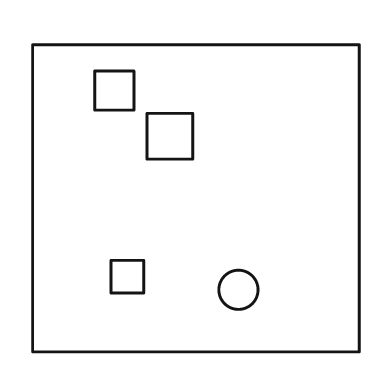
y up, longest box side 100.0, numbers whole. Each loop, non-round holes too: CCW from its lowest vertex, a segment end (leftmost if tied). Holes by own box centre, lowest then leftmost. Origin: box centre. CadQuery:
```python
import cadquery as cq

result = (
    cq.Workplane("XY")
    .moveTo(-50.0, -47.0)
    .lineTo(50.0, -47.0)
    .lineTo(50.0, 47.0)
    .lineTo(-50.0, 47.0)
    .close()
    .moveTo(13.0, -28.0)
    .circle(6.0)
    .moveTo(-26.0, -29.0)
    .lineTo(-16.0, -29.0)
    .lineTo(-16.0, -19.0)
    .lineTo(-26.0, -19.0)
    .close()
    .moveTo(-15.0, 12.0)
    .lineTo(-1.0, 12.0)
    .lineTo(-1.0, 26.0)
    .lineTo(-15.0, 26.0)
    .close()
    .moveTo(-31.0, 27.0)
    .lineTo(-19.0, 27.0)
    .lineTo(-19.0, 39.0)
    .lineTo(-31.0, 39.0)
    .close()
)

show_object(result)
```